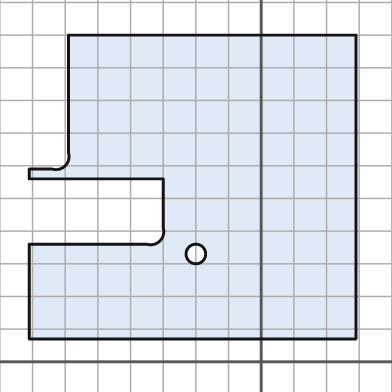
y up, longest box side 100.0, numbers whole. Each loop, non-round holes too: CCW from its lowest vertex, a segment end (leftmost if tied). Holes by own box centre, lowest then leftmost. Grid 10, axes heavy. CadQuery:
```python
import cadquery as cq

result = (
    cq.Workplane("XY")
    .moveTo(-71.0, 7.0)
    .lineTo(29.0, 7.0)
    .lineTo(29.0, 100.0)
    .lineTo(-59.0, 100.0)
    .lineTo(-59.0, 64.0)
    .threePointArc((-60.0, 60.0), (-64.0, 59.0))
    .lineTo(-71.0, 59.0)
    .lineTo(-71.0, 56.0)
    .lineTo(-30.0, 56.0)
    .lineTo(-30.0, 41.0)
    .threePointArc((-31.0, 37.0), (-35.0, 36.0))
    .lineTo(-71.0, 36.0)
    .close()
    .moveTo(-20.0, 33.0)
    .circle(3.0)
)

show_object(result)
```